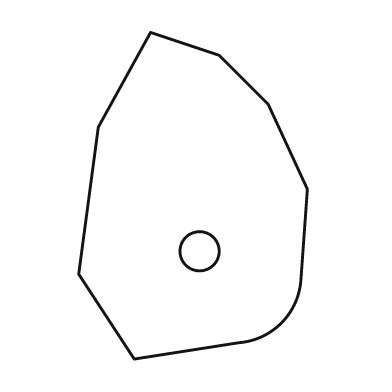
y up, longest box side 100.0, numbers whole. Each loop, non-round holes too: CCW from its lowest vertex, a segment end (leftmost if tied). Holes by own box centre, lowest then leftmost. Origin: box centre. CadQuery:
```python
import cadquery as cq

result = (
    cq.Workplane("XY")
    .moveTo(-18.0, -50.0)
    .lineTo(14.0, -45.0)
    .threePointArc((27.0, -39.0), (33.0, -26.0))
    .lineTo(35.0, 2.0)
    .lineTo(23.0, 28.0)
    .lineTo(8.0, 43.0)
    .lineTo(-13.0, 50.0)
    .lineTo(-29.0, 21.0)
    .lineTo(-35.0, -24.0)
    .close()
    .moveTo(2.0, -17.0)
    .circle(6.0)
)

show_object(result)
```